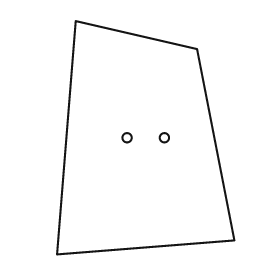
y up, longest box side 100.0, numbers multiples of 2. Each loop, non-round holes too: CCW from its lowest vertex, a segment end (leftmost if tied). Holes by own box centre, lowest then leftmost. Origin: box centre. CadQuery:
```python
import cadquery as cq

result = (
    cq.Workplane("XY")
    .moveTo(-38.0, -50.0)
    .lineTo(38.0, -44.0)
    .lineTo(22.0, 38.0)
    .lineTo(-30.0, 50.0)
    .close()
    .moveTo(-8.0, 0.0)
    .circle(2.0)
    .moveTo(8.0, 0.0)
    .circle(2.0)
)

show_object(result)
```